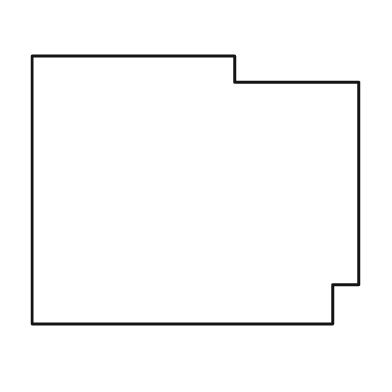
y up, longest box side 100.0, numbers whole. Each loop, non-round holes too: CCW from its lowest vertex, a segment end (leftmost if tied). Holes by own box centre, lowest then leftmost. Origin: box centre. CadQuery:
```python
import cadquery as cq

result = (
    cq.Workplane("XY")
    .moveTo(-50.0, -41.0)
    .lineTo(42.0, -41.0)
    .lineTo(42.0, -29.0)
    .lineTo(50.0, -29.0)
    .lineTo(50.0, 33.0)
    .lineTo(12.0, 33.0)
    .lineTo(12.0, 41.0)
    .lineTo(-50.0, 41.0)
    .close()
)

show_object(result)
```